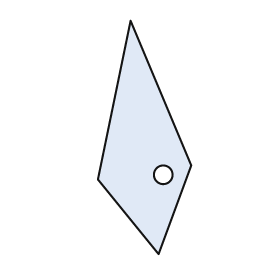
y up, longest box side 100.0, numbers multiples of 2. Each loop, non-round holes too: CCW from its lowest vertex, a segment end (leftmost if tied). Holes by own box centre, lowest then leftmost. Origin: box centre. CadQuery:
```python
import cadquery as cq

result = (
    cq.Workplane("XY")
    .moveTo(6.0, -50.0)
    .lineTo(20.0, -12.0)
    .lineTo(-6.0, 50.0)
    .lineTo(-20.0, -18.0)
    .close()
    .moveTo(8.0, -16.0)
    .circle(4.0)
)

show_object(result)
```